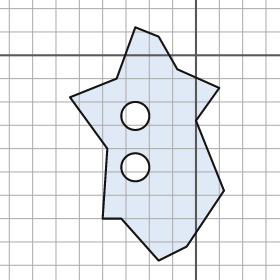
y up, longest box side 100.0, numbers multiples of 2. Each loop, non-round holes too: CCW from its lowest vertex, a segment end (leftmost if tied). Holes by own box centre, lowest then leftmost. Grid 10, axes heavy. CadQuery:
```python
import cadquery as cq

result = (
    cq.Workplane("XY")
    .moveTo(-16.0, -88.0)
    .lineTo(-4.0, -82.0)
    .lineTo(12.0, -58.0)
    .lineTo(0.0, -28.0)
    .lineTo(10.0, -14.0)
    .lineTo(-8.0, -6.0)
    .lineTo(-16.0, 8.0)
    .lineTo(-26.0, 12.0)
    .lineTo(-34.0, -10.0)
    .lineTo(-54.0, -18.0)
    .lineTo(-38.0, -40.0)
    .lineTo(-40.0, -70.0)
    .lineTo(-32.0, -70.0)
    .close()
    .moveTo(-26.0, -48.0)
    .circle(6.0)
    .moveTo(-26.0, -26.0)
    .circle(6.0)
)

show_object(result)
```